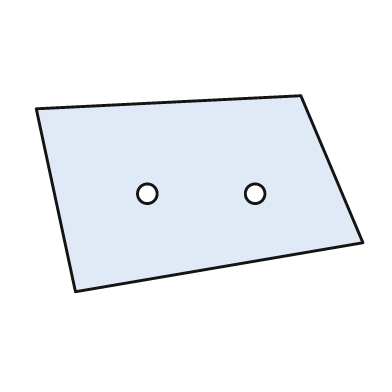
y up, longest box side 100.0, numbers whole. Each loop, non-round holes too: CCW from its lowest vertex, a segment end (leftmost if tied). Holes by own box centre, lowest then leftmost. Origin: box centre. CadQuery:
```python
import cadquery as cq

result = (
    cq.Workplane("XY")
    .moveTo(-38.0, -30.0)
    .lineTo(50.0, -15.0)
    .lineTo(31.0, 30.0)
    .lineTo(-50.0, 26.0)
    .close()
    .moveTo(-16.0, 0.0)
    .circle(3.0)
    .moveTo(17.0, 0.0)
    .circle(3.0)
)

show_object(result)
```